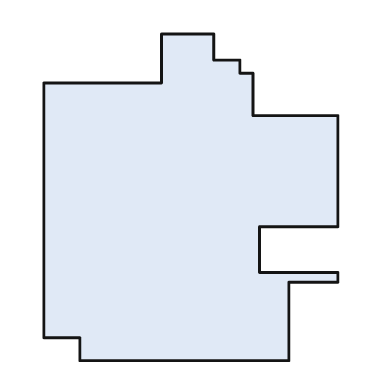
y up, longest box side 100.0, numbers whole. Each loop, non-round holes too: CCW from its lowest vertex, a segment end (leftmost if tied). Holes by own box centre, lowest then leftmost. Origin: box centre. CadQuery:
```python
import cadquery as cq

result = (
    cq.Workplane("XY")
    .moveTo(-34.0, -50.0)
    .lineTo(30.0, -50.0)
    .lineTo(30.0, -26.0)
    .lineTo(45.0, -26.0)
    .lineTo(45.0, -23.0)
    .lineTo(21.0, -23.0)
    .lineTo(21.0, -9.0)
    .lineTo(45.0, -9.0)
    .lineTo(45.0, 25.0)
    .lineTo(19.0, 25.0)
    .lineTo(19.0, 38.0)
    .lineTo(15.0, 38.0)
    .lineTo(15.0, 42.0)
    .lineTo(7.0, 42.0)
    .lineTo(7.0, 50.0)
    .lineTo(-9.0, 50.0)
    .lineTo(-9.0, 35.0)
    .lineTo(-45.0, 35.0)
    .lineTo(-45.0, -43.0)
    .lineTo(-34.0, -43.0)
    .close()
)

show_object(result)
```